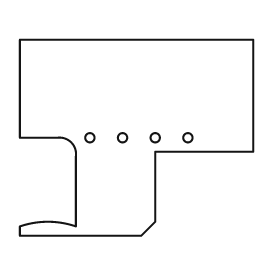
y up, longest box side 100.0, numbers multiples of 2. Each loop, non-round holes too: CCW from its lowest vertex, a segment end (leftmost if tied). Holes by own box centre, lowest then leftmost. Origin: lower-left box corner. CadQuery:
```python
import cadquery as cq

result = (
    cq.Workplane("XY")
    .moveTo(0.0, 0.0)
    .lineTo(52.0, 0.0)
    .lineTo(58.0, 6.0)
    .lineTo(58.0, 36.0)
    .lineTo(100.0, 36.0)
    .lineTo(100.0, 84.0)
    .lineTo(0.0, 84.0)
    .lineTo(0.0, 42.0)
    .lineTo(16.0, 42.0)
    .threePointArc((22.0, 40.0), (24.0, 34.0))
    .lineTo(24.0, 4.0)
    .threePointArc((12.0, 6.0), (0.0, 4.0))
    .close()
    .moveTo(30.0, 42.0)
    .circle(2.0)
    .moveTo(44.0, 42.0)
    .circle(2.0)
    .moveTo(58.0, 42.0)
    .circle(2.0)
    .moveTo(72.0, 42.0)
    .circle(2.0)
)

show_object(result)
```